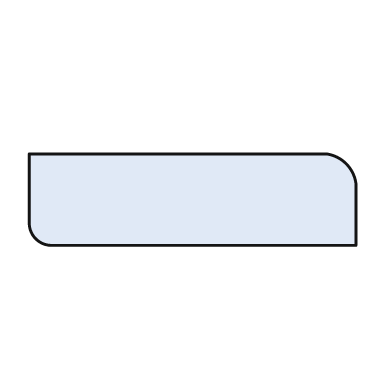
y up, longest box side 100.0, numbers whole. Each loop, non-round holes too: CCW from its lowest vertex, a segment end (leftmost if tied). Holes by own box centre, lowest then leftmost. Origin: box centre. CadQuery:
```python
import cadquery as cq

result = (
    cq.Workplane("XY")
    .moveTo(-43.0, -14.0)
    .lineTo(50.0, -14.0)
    .lineTo(50.0, 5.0)
    .threePointArc((47.0, 11.0), (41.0, 14.0))
    .lineTo(-50.0, 14.0)
    .lineTo(-50.0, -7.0)
    .threePointArc((-48.0, -12.0), (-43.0, -14.0))
    .close()
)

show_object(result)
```